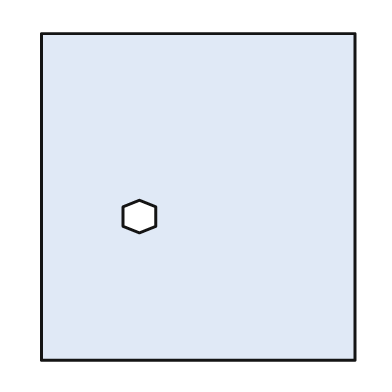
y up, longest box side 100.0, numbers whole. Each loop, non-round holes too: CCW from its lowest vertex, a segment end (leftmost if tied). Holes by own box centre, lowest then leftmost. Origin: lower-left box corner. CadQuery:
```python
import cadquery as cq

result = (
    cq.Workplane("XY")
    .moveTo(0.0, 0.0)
    .lineTo(96.0, 0.0)
    .lineTo(96.0, 100.0)
    .lineTo(0.0, 100.0)
    .close()
    .moveTo(30.0, 39.0)
    .lineTo(35.0, 41.0)
    .lineTo(35.0, 47.0)
    .lineTo(30.0, 49.0)
    .lineTo(25.0, 47.0)
    .lineTo(25.0, 41.0)
    .close()
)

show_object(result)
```